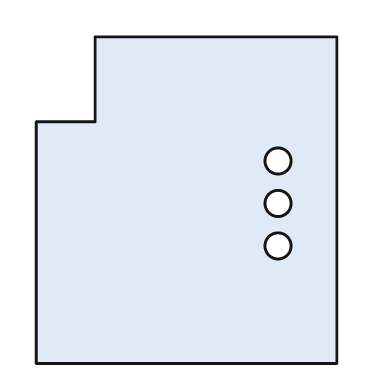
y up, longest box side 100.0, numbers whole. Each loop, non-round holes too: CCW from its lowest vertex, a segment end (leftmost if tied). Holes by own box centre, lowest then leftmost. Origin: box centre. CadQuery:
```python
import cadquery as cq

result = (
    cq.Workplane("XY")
    .moveTo(-46.0, -50.0)
    .lineTo(46.0, -50.0)
    .lineTo(46.0, 50.0)
    .lineTo(-28.0, 50.0)
    .lineTo(-28.0, 24.0)
    .lineTo(-46.0, 24.0)
    .close()
    .moveTo(28.0, -14.0)
    .circle(4.0)
    .moveTo(28.0, -1.0)
    .circle(4.0)
    .moveTo(28.0, 12.0)
    .circle(4.0)
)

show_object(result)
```